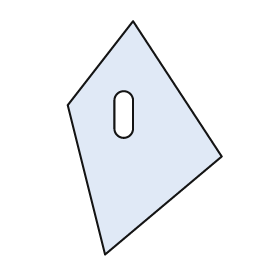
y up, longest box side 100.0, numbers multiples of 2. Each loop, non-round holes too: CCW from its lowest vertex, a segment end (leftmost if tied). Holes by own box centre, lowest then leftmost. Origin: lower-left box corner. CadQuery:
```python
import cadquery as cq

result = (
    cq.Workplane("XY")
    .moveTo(16.0, 0.0)
    .lineTo(66.0, 42.0)
    .lineTo(28.0, 100.0)
    .lineTo(0.0, 64.0)
    .close()
    .moveTo(20.0, 54.0)
    .threePointArc((24.0, 50.0), (28.0, 54.0))
    .lineTo(28.0, 66.0)
    .threePointArc((24.0, 70.0), (20.0, 66.0))
    .close()
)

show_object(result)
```